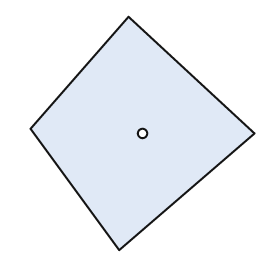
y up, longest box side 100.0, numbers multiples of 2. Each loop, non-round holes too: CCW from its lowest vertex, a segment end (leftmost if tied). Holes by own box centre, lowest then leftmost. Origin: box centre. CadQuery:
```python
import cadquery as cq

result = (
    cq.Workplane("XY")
    .moveTo(-10.0, -50.0)
    .lineTo(48.0, 0.0)
    .lineTo(-6.0, 50.0)
    .lineTo(-48.0, 2.0)
    .close()
    .moveTo(0.0, 0.0)
    .circle(2.0)
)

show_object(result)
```